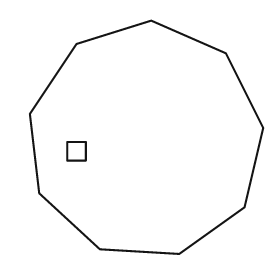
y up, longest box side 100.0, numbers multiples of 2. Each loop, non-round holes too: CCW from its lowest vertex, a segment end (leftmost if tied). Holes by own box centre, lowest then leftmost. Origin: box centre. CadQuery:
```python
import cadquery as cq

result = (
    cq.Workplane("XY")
    .moveTo(14.0, -50.0)
    .lineTo(42.0, -30.0)
    .lineTo(50.0, 4.0)
    .lineTo(34.0, 36.0)
    .lineTo(2.0, 50.0)
    .lineTo(-30.0, 40.0)
    .lineTo(-50.0, 10.0)
    .lineTo(-46.0, -24.0)
    .lineTo(-20.0, -48.0)
    .close()
    .moveTo(-34.0, -10.0)
    .lineTo(-26.0, -10.0)
    .lineTo(-26.0, -2.0)
    .lineTo(-34.0, -2.0)
    .close()
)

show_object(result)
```